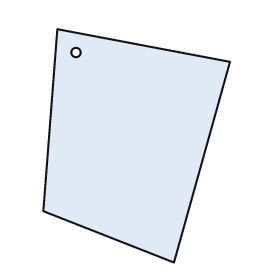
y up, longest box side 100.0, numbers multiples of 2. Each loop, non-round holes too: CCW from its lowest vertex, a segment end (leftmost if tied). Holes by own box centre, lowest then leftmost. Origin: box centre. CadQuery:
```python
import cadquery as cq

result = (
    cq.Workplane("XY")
    .moveTo(16.0, -50.0)
    .lineTo(40.0, 36.0)
    .lineTo(-34.0, 50.0)
    .lineTo(-40.0, -28.0)
    .close()
    .moveTo(-26.0, 40.0)
    .circle(2.0)
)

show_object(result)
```